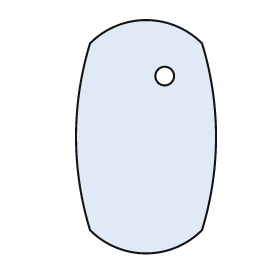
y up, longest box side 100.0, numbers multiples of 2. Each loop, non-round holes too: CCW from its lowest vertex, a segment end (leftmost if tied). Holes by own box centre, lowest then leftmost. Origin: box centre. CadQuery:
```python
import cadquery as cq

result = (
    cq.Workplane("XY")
    .moveTo(-24.0, -40.0)
    .threePointArc((0.0, -50.0), (24.0, -40.0))
    .threePointArc((30.0, 0.0), (24.0, 40.0))
    .threePointArc((0.0, 50.0), (-24.0, 40.0))
    .threePointArc((-30.0, 0.0), (-24.0, -40.0))
    .close()
    .moveTo(8.0, 26.0)
    .circle(4.0)
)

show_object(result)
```